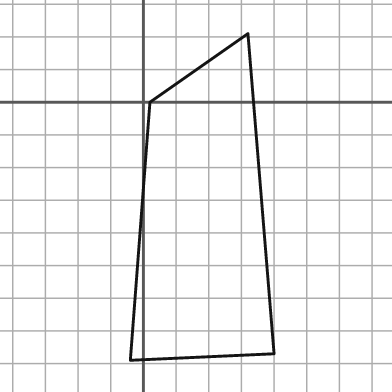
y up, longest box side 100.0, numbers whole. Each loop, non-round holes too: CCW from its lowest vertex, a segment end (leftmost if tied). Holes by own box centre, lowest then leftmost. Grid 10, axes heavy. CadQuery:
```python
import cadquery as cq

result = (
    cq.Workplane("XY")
    .moveTo(-4.0, -79.0)
    .lineTo(40.0, -77.0)
    .lineTo(32.0, 21.0)
    .lineTo(2.0, 0.0)
    .close()
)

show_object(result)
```